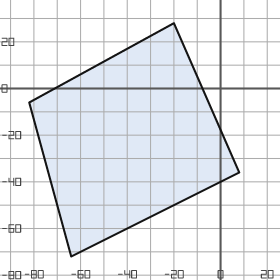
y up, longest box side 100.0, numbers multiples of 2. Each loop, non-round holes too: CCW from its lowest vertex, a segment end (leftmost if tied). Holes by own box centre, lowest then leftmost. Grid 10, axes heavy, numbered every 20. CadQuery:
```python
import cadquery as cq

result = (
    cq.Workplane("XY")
    .moveTo(-64.0, -72.0)
    .lineTo(8.0, -36.0)
    .lineTo(-20.0, 28.0)
    .lineTo(-82.0, -6.0)
    .close()
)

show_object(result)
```